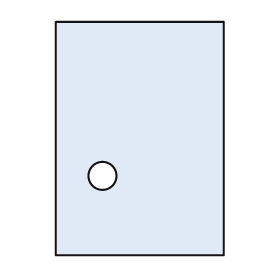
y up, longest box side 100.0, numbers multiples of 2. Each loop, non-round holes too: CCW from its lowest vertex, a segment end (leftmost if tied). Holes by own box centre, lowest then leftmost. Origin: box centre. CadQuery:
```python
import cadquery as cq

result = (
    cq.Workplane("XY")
    .moveTo(-36.0, -50.0)
    .lineTo(36.0, -50.0)
    .lineTo(36.0, 50.0)
    .lineTo(-36.0, 50.0)
    .close()
    .moveTo(-16.0, -16.0)
    .circle(6.0)
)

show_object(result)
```